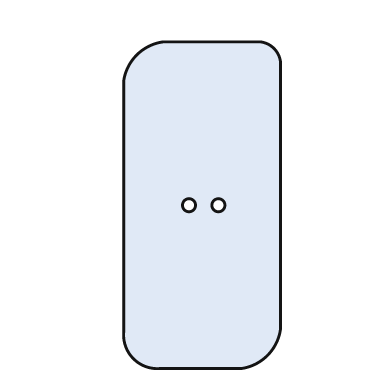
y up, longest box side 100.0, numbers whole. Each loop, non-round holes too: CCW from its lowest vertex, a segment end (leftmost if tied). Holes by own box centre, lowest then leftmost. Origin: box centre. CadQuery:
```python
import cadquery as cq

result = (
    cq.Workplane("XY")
    .moveTo(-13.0, -50.0)
    .lineTo(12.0, -50.0)
    .threePointArc((20.0, -46.0), (24.0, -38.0))
    .lineTo(24.0, 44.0)
    .threePointArc((22.0, 48.0), (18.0, 50.0))
    .lineTo(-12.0, 50.0)
    .threePointArc((-20.0, 46.0), (-24.0, 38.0))
    .lineTo(-24.0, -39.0)
    .threePointArc((-21.0, -47.0), (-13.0, -50.0))
    .close()
    .moveTo(-4.0, 0.0)
    .circle(2.0)
    .moveTo(5.0, 0.0)
    .circle(2.0)
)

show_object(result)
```